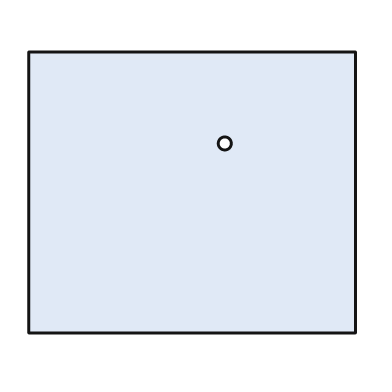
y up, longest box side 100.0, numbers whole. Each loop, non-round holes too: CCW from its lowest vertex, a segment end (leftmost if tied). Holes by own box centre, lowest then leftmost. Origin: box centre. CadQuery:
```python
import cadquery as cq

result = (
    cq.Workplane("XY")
    .moveTo(-50.0, -43.0)
    .lineTo(50.0, -43.0)
    .lineTo(50.0, 43.0)
    .lineTo(-50.0, 43.0)
    .close()
    .moveTo(10.0, 15.0)
    .circle(2.0)
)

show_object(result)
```